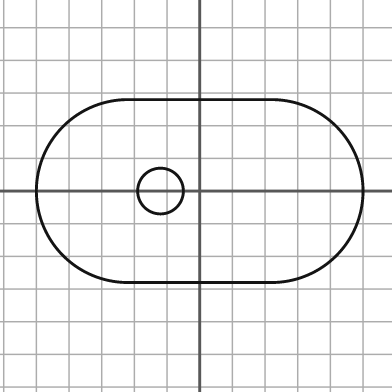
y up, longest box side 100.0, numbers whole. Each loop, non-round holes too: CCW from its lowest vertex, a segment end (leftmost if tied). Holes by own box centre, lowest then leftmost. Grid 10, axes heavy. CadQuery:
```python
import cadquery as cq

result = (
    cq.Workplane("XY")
    .moveTo(-22.0, -28.0)
    .lineTo(22.0, -28.0)
    .threePointArc((50.0, 0.0), (22.0, 28.0))
    .lineTo(-22.0, 28.0)
    .threePointArc((-50.0, 0.0), (-22.0, -28.0))
    .close()
    .moveTo(-12.0, 0.0)
    .circle(7.0)
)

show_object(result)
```